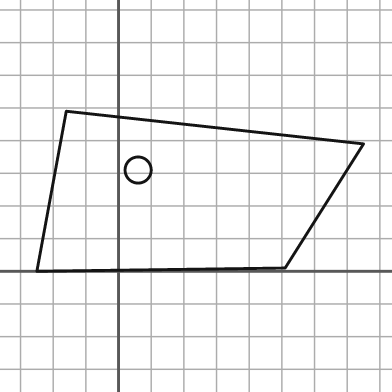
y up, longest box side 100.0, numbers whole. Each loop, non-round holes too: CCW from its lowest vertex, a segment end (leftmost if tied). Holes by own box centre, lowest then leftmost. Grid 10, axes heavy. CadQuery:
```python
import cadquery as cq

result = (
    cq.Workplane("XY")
    .moveTo(-25.0, 0.0)
    .lineTo(51.0, 1.0)
    .lineTo(75.0, 39.0)
    .lineTo(-16.0, 49.0)
    .close()
    .moveTo(6.0, 31.0)
    .circle(4.0)
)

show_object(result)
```